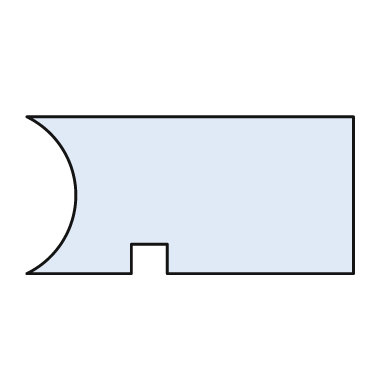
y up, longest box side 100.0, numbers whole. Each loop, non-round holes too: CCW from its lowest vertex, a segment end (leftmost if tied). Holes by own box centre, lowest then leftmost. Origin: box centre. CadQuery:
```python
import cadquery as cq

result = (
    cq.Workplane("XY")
    .moveTo(-50.0, -24.0)
    .lineTo(-18.0, -24.0)
    .lineTo(-18.0, -15.0)
    .lineTo(-7.0, -15.0)
    .lineTo(-7.0, -24.0)
    .lineTo(50.0, -24.0)
    .lineTo(50.0, 24.0)
    .lineTo(-50.0, 24.0)
    .threePointArc((-35.0, 0.0), (-50.0, -24.0))
    .close()
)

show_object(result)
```